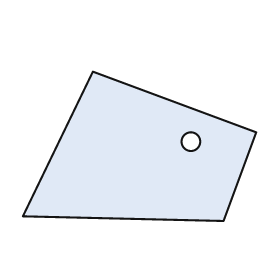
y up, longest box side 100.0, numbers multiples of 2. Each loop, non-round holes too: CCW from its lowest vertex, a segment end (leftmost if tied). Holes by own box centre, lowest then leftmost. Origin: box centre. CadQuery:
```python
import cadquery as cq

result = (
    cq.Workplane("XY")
    .moveTo(36.0, -32.0)
    .lineTo(50.0, 6.0)
    .lineTo(-20.0, 32.0)
    .lineTo(-50.0, -30.0)
    .close()
    .moveTo(22.0, 2.0)
    .circle(4.0)
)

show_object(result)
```